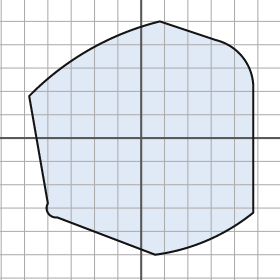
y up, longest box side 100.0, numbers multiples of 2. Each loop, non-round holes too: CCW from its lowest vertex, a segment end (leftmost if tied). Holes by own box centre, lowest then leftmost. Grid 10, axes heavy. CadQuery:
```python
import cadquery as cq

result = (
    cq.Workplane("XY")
    .moveTo(6.0, -50.0)
    .threePointArc((28.0, -44.0), (48.0, -32.0))
    .lineTo(48.0, 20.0)
    .threePointArc((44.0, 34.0), (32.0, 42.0))
    .lineTo(8.0, 50.0)
    .threePointArc((-22.0, 38.0), (-48.0, 18.0))
    .lineTo(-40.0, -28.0)
    .threePointArc((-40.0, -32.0), (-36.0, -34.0))
    .close()
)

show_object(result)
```